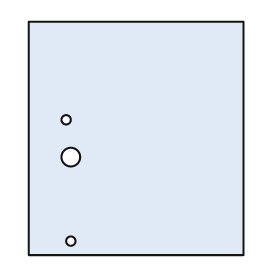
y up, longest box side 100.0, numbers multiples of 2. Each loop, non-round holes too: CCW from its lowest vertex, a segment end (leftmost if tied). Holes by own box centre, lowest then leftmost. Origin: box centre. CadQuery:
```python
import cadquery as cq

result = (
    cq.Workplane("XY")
    .moveTo(-46.0, -50.0)
    .lineTo(46.0, -50.0)
    .lineTo(46.0, 50.0)
    .lineTo(-46.0, 50.0)
    .close()
    .moveTo(-28.0, -44.0)
    .circle(2.0)
    .moveTo(-28.0, -8.0)
    .circle(4.0)
    .moveTo(-30.0, 8.0)
    .circle(2.0)
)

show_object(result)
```